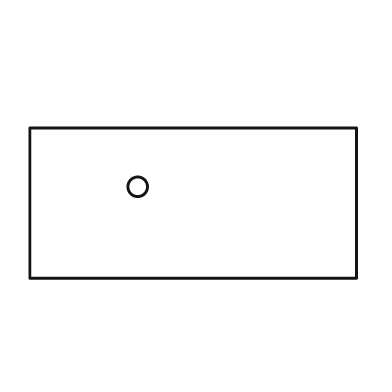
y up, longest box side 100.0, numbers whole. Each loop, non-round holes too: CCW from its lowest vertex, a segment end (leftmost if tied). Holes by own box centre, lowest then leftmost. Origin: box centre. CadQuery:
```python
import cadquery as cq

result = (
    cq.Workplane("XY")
    .moveTo(-50.0, -23.0)
    .lineTo(50.0, -23.0)
    .lineTo(50.0, 23.0)
    .lineTo(-50.0, 23.0)
    .close()
    .moveTo(-17.0, 5.0)
    .circle(3.0)
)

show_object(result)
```